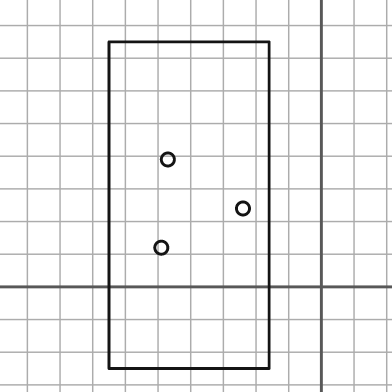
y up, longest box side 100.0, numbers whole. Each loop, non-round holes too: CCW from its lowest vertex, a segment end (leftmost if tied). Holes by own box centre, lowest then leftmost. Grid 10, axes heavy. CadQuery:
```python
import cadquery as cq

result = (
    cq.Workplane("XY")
    .moveTo(-65.0, -25.0)
    .lineTo(-16.0, -25.0)
    .lineTo(-16.0, 75.0)
    .lineTo(-65.0, 75.0)
    .close()
    .moveTo(-49.0, 12.0)
    .circle(2.0)
    .moveTo(-24.0, 24.0)
    .circle(2.0)
    .moveTo(-47.0, 39.0)
    .circle(2.0)
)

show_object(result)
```